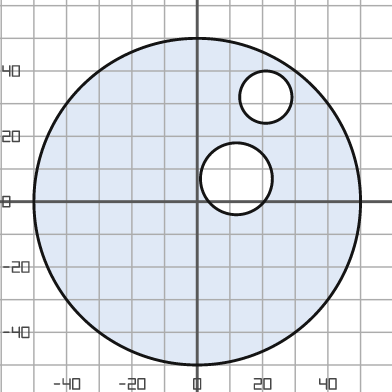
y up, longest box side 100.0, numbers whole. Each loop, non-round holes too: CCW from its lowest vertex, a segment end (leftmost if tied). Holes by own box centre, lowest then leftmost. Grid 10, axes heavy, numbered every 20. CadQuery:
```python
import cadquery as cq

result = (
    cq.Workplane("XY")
    .moveTo(0.0, 0.0)
    .circle(50.0)
    .moveTo(12.0, 7.0)
    .circle(11.0)
    .moveTo(21.0, 32.0)
    .circle(8.0)
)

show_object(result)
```